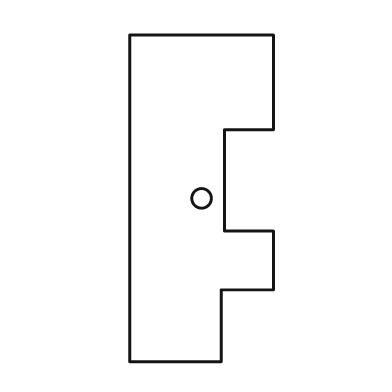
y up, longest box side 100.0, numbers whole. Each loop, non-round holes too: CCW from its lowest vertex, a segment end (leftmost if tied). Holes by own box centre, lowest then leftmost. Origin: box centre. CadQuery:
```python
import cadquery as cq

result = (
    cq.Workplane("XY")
    .moveTo(-22.0, -50.0)
    .lineTo(6.0, -50.0)
    .lineTo(6.0, -28.0)
    .lineTo(22.0, -28.0)
    .lineTo(22.0, -10.0)
    .lineTo(7.0, -10.0)
    .lineTo(7.0, 21.0)
    .lineTo(22.0, 21.0)
    .lineTo(22.0, 50.0)
    .lineTo(-22.0, 50.0)
    .close()
    .moveTo(0.0, 0.0)
    .circle(3.0)
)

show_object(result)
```